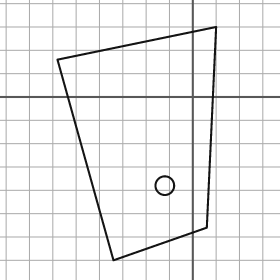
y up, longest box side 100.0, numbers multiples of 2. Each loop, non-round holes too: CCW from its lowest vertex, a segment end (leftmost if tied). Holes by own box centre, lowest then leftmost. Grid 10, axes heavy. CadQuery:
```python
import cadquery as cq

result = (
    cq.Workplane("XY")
    .moveTo(-34.0, -70.0)
    .lineTo(6.0, -56.0)
    .lineTo(10.0, 30.0)
    .lineTo(-58.0, 16.0)
    .close()
    .moveTo(-12.0, -38.0)
    .circle(4.0)
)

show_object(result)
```